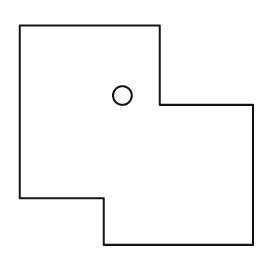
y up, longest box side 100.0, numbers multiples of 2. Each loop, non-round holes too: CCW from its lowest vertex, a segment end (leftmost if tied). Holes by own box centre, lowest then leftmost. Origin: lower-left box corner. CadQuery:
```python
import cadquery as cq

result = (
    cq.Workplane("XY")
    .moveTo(36.0, 0.0)
    .lineTo(100.0, 0.0)
    .lineTo(100.0, 60.0)
    .lineTo(60.0, 60.0)
    .lineTo(60.0, 94.0)
    .lineTo(0.0, 94.0)
    .lineTo(0.0, 20.0)
    .lineTo(36.0, 20.0)
    .close()
    .moveTo(44.0, 64.0)
    .circle(4.0)
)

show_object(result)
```